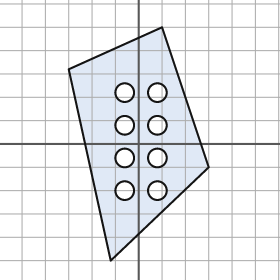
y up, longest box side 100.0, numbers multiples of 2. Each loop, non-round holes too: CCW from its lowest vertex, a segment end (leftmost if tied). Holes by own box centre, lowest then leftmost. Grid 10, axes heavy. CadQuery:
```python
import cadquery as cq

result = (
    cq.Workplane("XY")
    .moveTo(-12.0, -50.0)
    .lineTo(30.0, -10.0)
    .lineTo(10.0, 50.0)
    .lineTo(-30.0, 32.0)
    .close()
    .moveTo(-6.0, -20.0)
    .circle(4.0)
    .moveTo(8.0, -20.0)
    .circle(4.0)
    .moveTo(-6.0, -6.0)
    .circle(4.0)
    .moveTo(8.0, -6.0)
    .circle(4.0)
    .moveTo(-6.0, 8.0)
    .circle(4.0)
    .moveTo(8.0, 8.0)
    .circle(4.0)
    .moveTo(-6.0, 22.0)
    .circle(4.0)
    .moveTo(8.0, 22.0)
    .circle(4.0)
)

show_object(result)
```